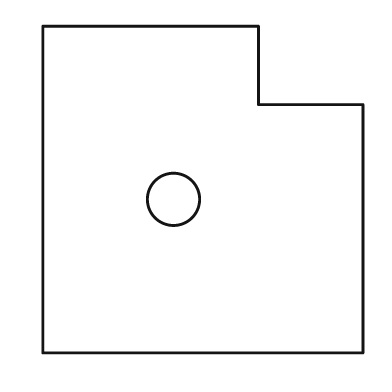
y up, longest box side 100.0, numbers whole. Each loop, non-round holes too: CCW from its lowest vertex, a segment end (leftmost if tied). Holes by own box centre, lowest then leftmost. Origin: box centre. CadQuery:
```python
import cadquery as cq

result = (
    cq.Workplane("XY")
    .moveTo(-49.0, -50.0)
    .lineTo(49.0, -50.0)
    .lineTo(49.0, 26.0)
    .lineTo(17.0, 26.0)
    .lineTo(17.0, 50.0)
    .lineTo(-49.0, 50.0)
    .close()
    .moveTo(-9.0, -3.0)
    .circle(8.0)
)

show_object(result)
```